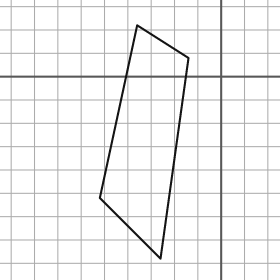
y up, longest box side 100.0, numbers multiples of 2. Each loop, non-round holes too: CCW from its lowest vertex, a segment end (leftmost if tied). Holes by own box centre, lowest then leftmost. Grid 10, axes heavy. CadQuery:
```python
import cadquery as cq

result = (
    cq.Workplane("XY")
    .moveTo(-26.0, -78.0)
    .lineTo(-14.0, 8.0)
    .lineTo(-36.0, 22.0)
    .lineTo(-52.0, -52.0)
    .close()
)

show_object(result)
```